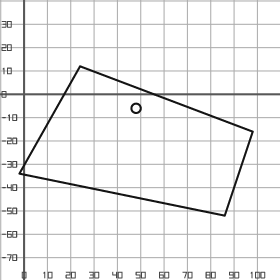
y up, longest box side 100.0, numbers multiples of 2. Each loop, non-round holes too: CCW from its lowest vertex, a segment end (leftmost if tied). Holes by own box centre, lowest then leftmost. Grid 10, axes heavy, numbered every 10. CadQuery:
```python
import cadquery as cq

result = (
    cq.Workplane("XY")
    .moveTo(86.0, -52.0)
    .lineTo(98.0, -16.0)
    .lineTo(24.0, 12.0)
    .lineTo(-2.0, -34.0)
    .close()
    .moveTo(48.0, -6.0)
    .circle(2.0)
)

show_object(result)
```